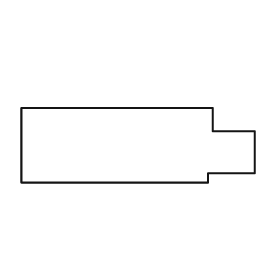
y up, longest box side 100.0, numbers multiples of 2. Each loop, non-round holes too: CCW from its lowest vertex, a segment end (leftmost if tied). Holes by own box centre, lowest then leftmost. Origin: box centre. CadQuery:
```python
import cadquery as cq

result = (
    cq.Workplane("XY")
    .moveTo(-50.0, -16.0)
    .lineTo(30.0, -16.0)
    .lineTo(30.0, -12.0)
    .lineTo(50.0, -12.0)
    .lineTo(50.0, 6.0)
    .lineTo(32.0, 6.0)
    .lineTo(32.0, 16.0)
    .lineTo(-50.0, 16.0)
    .close()
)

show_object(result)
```